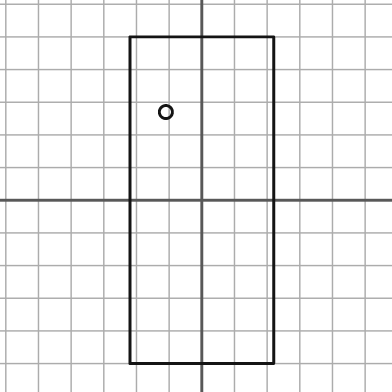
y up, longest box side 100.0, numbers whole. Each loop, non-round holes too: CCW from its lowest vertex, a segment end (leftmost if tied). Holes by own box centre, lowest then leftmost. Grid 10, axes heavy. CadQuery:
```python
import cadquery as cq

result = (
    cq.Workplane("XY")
    .moveTo(-22.0, -50.0)
    .lineTo(22.0, -50.0)
    .lineTo(22.0, 50.0)
    .lineTo(-22.0, 50.0)
    .close()
    .moveTo(-11.0, 27.0)
    .circle(2.0)
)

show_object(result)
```